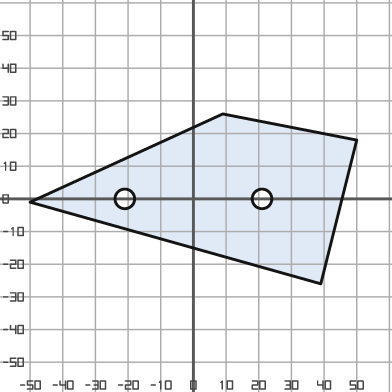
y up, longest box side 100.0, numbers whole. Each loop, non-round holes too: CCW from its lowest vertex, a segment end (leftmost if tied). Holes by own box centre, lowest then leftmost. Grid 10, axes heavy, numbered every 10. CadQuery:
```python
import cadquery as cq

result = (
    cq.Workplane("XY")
    .moveTo(39.0, -26.0)
    .lineTo(50.0, 18.0)
    .lineTo(9.0, 26.0)
    .lineTo(-50.0, -1.0)
    .close()
    .moveTo(-21.0, 0.0)
    .circle(3.0)
    .moveTo(21.0, 0.0)
    .circle(3.0)
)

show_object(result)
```